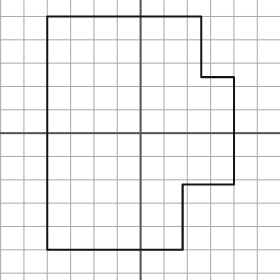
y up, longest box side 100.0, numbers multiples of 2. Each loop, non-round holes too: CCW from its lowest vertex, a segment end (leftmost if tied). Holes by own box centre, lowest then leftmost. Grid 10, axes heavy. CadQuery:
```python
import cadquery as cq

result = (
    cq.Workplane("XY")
    .moveTo(-40.0, -50.0)
    .lineTo(18.0, -50.0)
    .lineTo(18.0, -22.0)
    .lineTo(40.0, -22.0)
    .lineTo(40.0, 24.0)
    .lineTo(26.0, 24.0)
    .lineTo(26.0, 50.0)
    .lineTo(-40.0, 50.0)
    .close()
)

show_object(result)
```